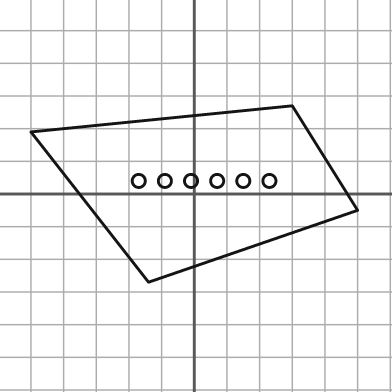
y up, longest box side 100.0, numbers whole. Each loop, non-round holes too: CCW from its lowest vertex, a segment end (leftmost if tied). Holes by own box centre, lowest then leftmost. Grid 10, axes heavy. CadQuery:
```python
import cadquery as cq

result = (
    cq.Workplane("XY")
    .moveTo(-14.0, -27.0)
    .lineTo(50.0, -5.0)
    .lineTo(30.0, 27.0)
    .lineTo(-50.0, 19.0)
    .close()
    .moveTo(-17.0, 4.0)
    .circle(2.0)
    .moveTo(-9.0, 4.0)
    .circle(2.0)
    .moveTo(-1.0, 4.0)
    .circle(2.0)
    .moveTo(7.0, 4.0)
    .circle(2.0)
    .moveTo(15.0, 4.0)
    .circle(2.0)
    .moveTo(23.0, 4.0)
    .circle(2.0)
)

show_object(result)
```